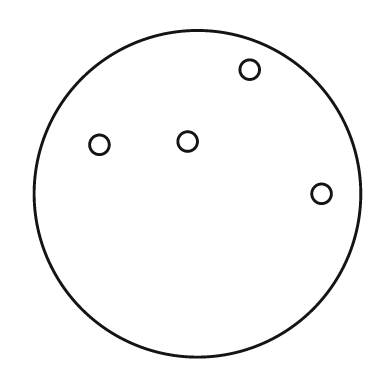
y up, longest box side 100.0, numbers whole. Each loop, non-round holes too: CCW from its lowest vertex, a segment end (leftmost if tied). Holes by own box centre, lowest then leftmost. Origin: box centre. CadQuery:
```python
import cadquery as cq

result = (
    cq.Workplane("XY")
    .moveTo(0.0, 0.0)
    .circle(50.0)
    .moveTo(38.0, 0.0)
    .circle(3.0)
    .moveTo(-30.0, 15.0)
    .circle(3.0)
    .moveTo(-3.0, 16.0)
    .circle(3.0)
    .moveTo(16.0, 38.0)
    .circle(3.0)
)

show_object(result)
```